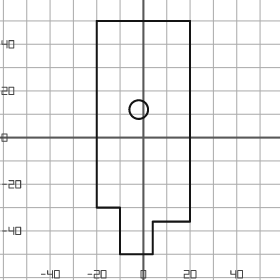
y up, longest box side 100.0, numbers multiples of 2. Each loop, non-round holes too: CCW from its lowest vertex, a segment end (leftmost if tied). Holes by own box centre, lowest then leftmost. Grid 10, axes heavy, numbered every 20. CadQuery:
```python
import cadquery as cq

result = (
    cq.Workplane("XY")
    .moveTo(-10.0, -50.0)
    .lineTo(4.0, -50.0)
    .lineTo(4.0, -36.0)
    .lineTo(20.0, -36.0)
    .lineTo(20.0, 50.0)
    .lineTo(-20.0, 50.0)
    .lineTo(-20.0, -30.0)
    .lineTo(-10.0, -30.0)
    .close()
    .moveTo(-2.0, 12.0)
    .circle(4.0)
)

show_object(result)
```